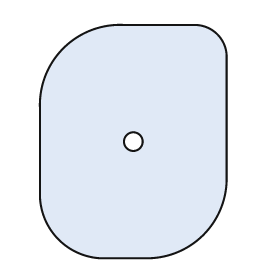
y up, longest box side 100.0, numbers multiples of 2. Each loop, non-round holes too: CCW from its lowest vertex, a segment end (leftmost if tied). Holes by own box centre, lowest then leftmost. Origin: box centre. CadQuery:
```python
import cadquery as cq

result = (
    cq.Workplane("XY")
    .moveTo(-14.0, -50.0)
    .lineTo(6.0, -50.0)
    .threePointArc((30.0, -40.0), (40.0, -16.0))
    .lineTo(40.0, 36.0)
    .threePointArc((36.0, 46.0), (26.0, 50.0))
    .lineTo(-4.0, 50.0)
    .threePointArc((-30.0, 40.0), (-40.0, 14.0))
    .lineTo(-40.0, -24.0)
    .threePointArc((-32.0, -42.0), (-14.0, -50.0))
    .close()
    .moveTo(0.0, 0.0)
    .circle(4.0)
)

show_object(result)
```